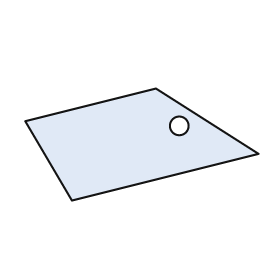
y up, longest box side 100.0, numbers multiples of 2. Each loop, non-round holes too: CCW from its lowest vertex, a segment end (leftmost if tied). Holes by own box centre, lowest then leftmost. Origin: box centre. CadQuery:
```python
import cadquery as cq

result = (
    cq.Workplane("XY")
    .moveTo(-30.0, -24.0)
    .lineTo(50.0, -4.0)
    .lineTo(6.0, 24.0)
    .lineTo(-50.0, 10.0)
    .close()
    .moveTo(16.0, 8.0)
    .circle(4.0)
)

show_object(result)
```